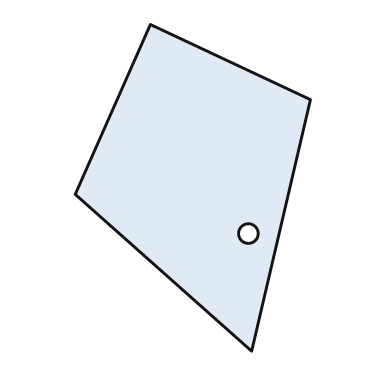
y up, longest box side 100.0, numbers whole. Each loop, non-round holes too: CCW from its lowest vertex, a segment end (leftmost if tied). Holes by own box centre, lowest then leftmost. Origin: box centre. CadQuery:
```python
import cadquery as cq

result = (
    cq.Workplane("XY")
    .moveTo(18.0, -50.0)
    .lineTo(36.0, 27.0)
    .lineTo(-13.0, 50.0)
    .lineTo(-36.0, -2.0)
    .close()
    .moveTo(17.0, -14.0)
    .circle(3.0)
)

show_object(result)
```